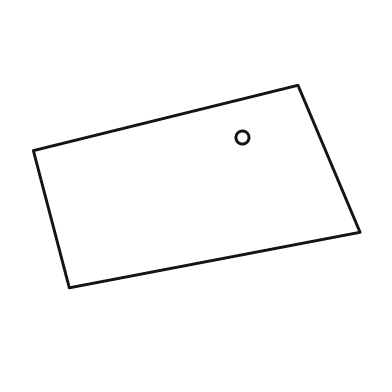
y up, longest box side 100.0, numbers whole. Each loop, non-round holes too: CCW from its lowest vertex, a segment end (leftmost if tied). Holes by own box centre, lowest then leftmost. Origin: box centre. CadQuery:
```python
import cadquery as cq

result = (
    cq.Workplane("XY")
    .moveTo(-39.0, -31.0)
    .lineTo(50.0, -14.0)
    .lineTo(31.0, 31.0)
    .lineTo(-50.0, 11.0)
    .close()
    .moveTo(14.0, 15.0)
    .circle(2.0)
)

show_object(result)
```